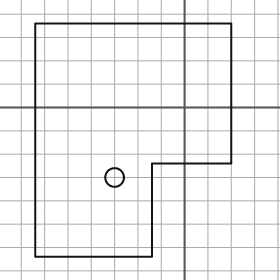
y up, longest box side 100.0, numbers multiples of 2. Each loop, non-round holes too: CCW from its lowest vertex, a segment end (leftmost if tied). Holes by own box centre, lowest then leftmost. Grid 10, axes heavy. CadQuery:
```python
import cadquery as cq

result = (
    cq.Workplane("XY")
    .moveTo(-64.0, -64.0)
    .lineTo(-14.0, -64.0)
    .lineTo(-14.0, -24.0)
    .lineTo(20.0, -24.0)
    .lineTo(20.0, 36.0)
    .lineTo(-64.0, 36.0)
    .close()
    .moveTo(-30.0, -30.0)
    .circle(4.0)
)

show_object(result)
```